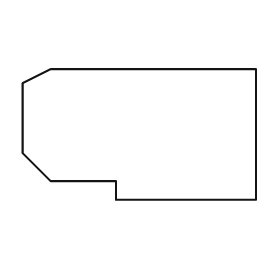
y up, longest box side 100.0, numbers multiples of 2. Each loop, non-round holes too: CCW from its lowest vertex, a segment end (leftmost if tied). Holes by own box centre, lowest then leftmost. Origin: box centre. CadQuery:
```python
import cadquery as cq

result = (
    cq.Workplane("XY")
    .moveTo(-10.0, -28.0)
    .lineTo(50.0, -28.0)
    .lineTo(50.0, 28.0)
    .lineTo(-38.0, 28.0)
    .lineTo(-50.0, 22.0)
    .lineTo(-50.0, -8.0)
    .lineTo(-38.0, -20.0)
    .lineTo(-10.0, -20.0)
    .close()
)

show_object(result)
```